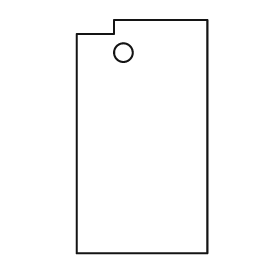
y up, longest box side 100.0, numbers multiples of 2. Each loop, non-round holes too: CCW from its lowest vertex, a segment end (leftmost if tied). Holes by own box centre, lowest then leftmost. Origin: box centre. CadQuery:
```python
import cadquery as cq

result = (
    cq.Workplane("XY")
    .moveTo(-28.0, -50.0)
    .lineTo(28.0, -50.0)
    .lineTo(28.0, 50.0)
    .lineTo(-12.0, 50.0)
    .lineTo(-12.0, 44.0)
    .lineTo(-28.0, 44.0)
    .close()
    .moveTo(-8.0, 36.0)
    .circle(4.0)
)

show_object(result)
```